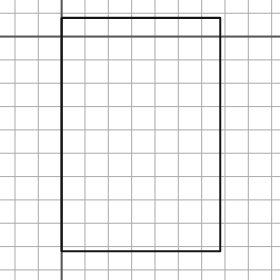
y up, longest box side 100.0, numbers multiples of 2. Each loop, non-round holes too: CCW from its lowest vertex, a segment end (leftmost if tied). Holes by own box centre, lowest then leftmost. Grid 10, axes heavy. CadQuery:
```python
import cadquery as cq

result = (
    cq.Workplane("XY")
    .moveTo(0.0, -92.0)
    .lineTo(68.0, -92.0)
    .lineTo(68.0, 8.0)
    .lineTo(0.0, 8.0)
    .close()
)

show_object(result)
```